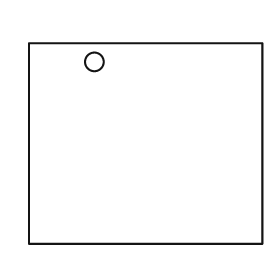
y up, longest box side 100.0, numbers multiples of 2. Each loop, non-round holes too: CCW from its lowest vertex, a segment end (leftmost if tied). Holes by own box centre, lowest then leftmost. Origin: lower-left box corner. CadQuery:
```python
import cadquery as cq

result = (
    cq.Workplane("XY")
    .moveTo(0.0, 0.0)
    .lineTo(100.0, 0.0)
    .lineTo(100.0, 86.0)
    .lineTo(0.0, 86.0)
    .close()
    .moveTo(28.0, 78.0)
    .circle(4.0)
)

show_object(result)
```